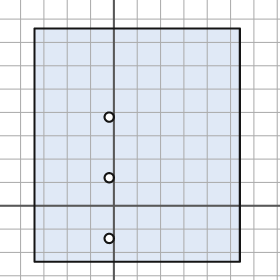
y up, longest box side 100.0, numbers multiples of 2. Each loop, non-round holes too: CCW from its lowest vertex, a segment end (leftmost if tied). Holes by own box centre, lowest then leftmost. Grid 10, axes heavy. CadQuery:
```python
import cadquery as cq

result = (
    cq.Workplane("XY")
    .moveTo(-34.0, -24.0)
    .lineTo(54.0, -24.0)
    .lineTo(54.0, 76.0)
    .lineTo(-34.0, 76.0)
    .close()
    .moveTo(-2.0, -14.0)
    .circle(2.0)
    .moveTo(-2.0, 12.0)
    .circle(2.0)
    .moveTo(-2.0, 38.0)
    .circle(2.0)
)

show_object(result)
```